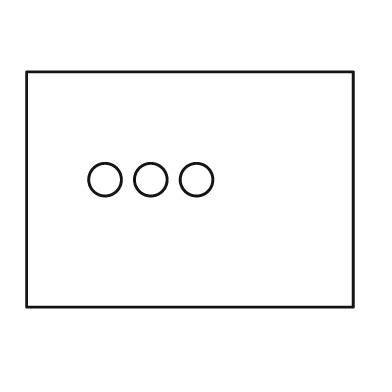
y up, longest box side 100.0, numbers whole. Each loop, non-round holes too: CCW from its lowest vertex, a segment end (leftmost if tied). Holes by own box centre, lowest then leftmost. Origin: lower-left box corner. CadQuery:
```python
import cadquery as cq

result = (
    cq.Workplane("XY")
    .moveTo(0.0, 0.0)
    .lineTo(100.0, 0.0)
    .lineTo(100.0, 72.0)
    .lineTo(0.0, 72.0)
    .close()
    .moveTo(24.0, 39.0)
    .circle(5.0)
    .moveTo(38.0, 39.0)
    .circle(5.0)
    .moveTo(52.0, 39.0)
    .circle(5.0)
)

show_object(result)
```